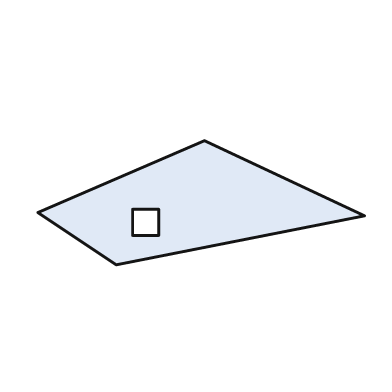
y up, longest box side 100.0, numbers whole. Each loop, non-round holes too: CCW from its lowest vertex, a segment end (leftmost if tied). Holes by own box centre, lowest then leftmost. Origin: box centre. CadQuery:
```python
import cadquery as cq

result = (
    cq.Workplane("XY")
    .moveTo(-26.0, -19.0)
    .lineTo(50.0, -4.0)
    .lineTo(1.0, 19.0)
    .lineTo(-50.0, -3.0)
    .close()
    .moveTo(-21.0, -10.0)
    .lineTo(-13.0, -10.0)
    .lineTo(-13.0, -2.0)
    .lineTo(-21.0, -2.0)
    .close()
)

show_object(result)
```